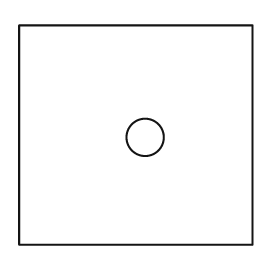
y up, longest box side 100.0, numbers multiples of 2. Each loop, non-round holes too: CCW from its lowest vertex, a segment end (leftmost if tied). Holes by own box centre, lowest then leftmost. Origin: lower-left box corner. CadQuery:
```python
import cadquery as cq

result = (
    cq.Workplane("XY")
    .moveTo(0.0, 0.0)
    .lineTo(100.0, 0.0)
    .lineTo(100.0, 94.0)
    .lineTo(0.0, 94.0)
    .close()
    .moveTo(54.0, 46.0)
    .circle(8.0)
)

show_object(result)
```